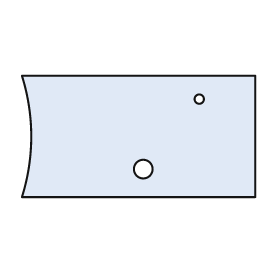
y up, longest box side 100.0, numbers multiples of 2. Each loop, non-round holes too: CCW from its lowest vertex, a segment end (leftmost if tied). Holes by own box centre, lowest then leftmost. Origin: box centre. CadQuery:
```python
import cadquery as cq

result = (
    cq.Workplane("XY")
    .moveTo(-50.0, -26.0)
    .lineTo(50.0, -26.0)
    .lineTo(50.0, 26.0)
    .lineTo(-50.0, 26.0)
    .threePointArc((-46.0, 0.0), (-50.0, -26.0))
    .close()
    .moveTo(2.0, -14.0)
    .circle(4.0)
    .moveTo(26.0, 16.0)
    .circle(2.0)
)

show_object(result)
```